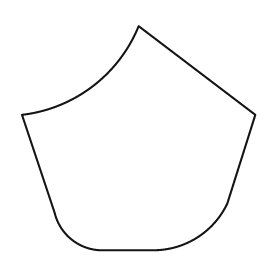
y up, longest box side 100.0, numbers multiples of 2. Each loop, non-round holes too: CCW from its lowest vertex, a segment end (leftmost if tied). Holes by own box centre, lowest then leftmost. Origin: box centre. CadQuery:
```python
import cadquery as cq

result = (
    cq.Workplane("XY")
    .moveTo(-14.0, -48.0)
    .lineTo(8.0, -48.0)
    .threePointArc((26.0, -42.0), (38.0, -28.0))
    .lineTo(50.0, 10.0)
    .lineTo(0.0, 48.0)
    .threePointArc((-20.0, 22.0), (-50.0, 10.0))
    .lineTo(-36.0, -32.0)
    .threePointArc((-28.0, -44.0), (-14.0, -48.0))
    .close()
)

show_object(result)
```